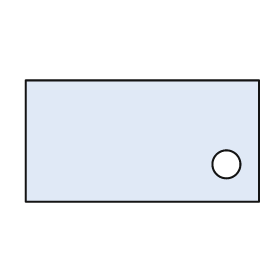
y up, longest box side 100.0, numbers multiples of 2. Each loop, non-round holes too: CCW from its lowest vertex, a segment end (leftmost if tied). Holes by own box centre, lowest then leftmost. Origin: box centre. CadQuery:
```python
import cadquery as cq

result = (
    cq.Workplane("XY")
    .moveTo(-50.0, -26.0)
    .lineTo(50.0, -26.0)
    .lineTo(50.0, 26.0)
    .lineTo(-50.0, 26.0)
    .close()
    .moveTo(36.0, -10.0)
    .circle(6.0)
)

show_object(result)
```